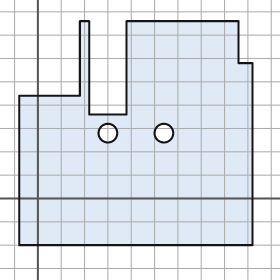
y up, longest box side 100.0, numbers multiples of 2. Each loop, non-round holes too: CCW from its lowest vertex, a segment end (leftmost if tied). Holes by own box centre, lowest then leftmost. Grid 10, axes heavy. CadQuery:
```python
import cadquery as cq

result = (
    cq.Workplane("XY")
    .moveTo(-8.0, -20.0)
    .lineTo(92.0, -20.0)
    .lineTo(92.0, 58.0)
    .lineTo(86.0, 58.0)
    .lineTo(86.0, 76.0)
    .lineTo(38.0, 76.0)
    .lineTo(38.0, 36.0)
    .lineTo(22.0, 36.0)
    .lineTo(22.0, 76.0)
    .lineTo(18.0, 76.0)
    .lineTo(18.0, 44.0)
    .lineTo(-8.0, 44.0)
    .close()
    .moveTo(30.0, 28.0)
    .circle(4.0)
    .moveTo(54.0, 28.0)
    .circle(4.0)
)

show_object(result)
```